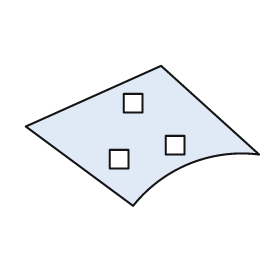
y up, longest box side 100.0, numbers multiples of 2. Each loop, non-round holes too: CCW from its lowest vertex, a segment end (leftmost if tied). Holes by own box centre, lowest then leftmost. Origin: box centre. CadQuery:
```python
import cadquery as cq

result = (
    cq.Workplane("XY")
    .moveTo(-4.0, -30.0)
    .threePointArc((20.0, -12.0), (50.0, -8.0))
    .lineTo(8.0, 30.0)
    .lineTo(-50.0, 4.0)
    .close()
    .moveTo(-14.0, -14.0)
    .lineTo(-6.0, -14.0)
    .lineTo(-6.0, -6.0)
    .lineTo(-14.0, -6.0)
    .close()
    .moveTo(10.0, -8.0)
    .lineTo(18.0, -8.0)
    .lineTo(18.0, 0.0)
    .lineTo(10.0, 0.0)
    .close()
    .moveTo(-8.0, 10.0)
    .lineTo(0.0, 10.0)
    .lineTo(0.0, 18.0)
    .lineTo(-8.0, 18.0)
    .close()
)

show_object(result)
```